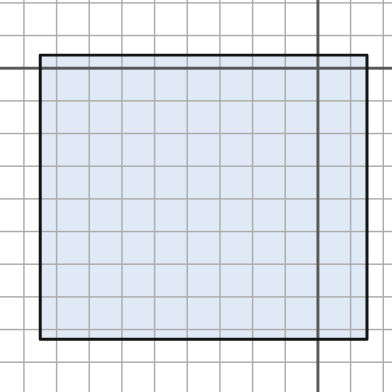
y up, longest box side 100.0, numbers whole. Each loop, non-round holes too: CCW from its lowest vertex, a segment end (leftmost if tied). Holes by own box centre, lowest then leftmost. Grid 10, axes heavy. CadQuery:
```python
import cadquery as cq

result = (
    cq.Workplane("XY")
    .moveTo(-85.0, -83.0)
    .lineTo(15.0, -83.0)
    .lineTo(15.0, 4.0)
    .lineTo(-85.0, 4.0)
    .close()
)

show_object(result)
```